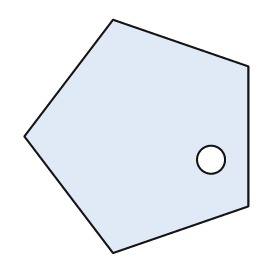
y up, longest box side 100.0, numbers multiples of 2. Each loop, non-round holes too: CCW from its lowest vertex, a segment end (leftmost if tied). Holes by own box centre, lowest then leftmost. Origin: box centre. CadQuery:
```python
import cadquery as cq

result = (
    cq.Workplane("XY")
    .moveTo(-10.0, -50.0)
    .lineTo(48.0, -30.0)
    .lineTo(48.0, 30.0)
    .lineTo(-10.0, 50.0)
    .lineTo(-48.0, 0.0)
    .close()
    .moveTo(32.0, -10.0)
    .circle(6.0)
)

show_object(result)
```